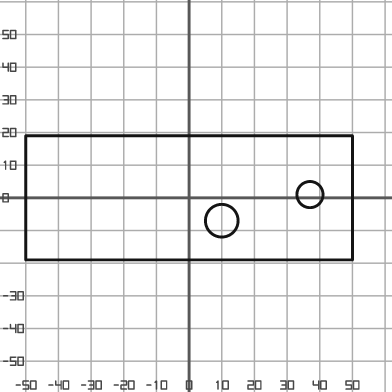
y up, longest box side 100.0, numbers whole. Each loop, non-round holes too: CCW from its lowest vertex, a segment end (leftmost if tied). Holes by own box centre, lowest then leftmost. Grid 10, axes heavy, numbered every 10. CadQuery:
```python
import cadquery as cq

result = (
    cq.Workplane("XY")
    .moveTo(-50.0, -19.0)
    .lineTo(50.0, -19.0)
    .lineTo(50.0, 19.0)
    .lineTo(-50.0, 19.0)
    .close()
    .moveTo(10.0, -7.0)
    .circle(5.0)
    .moveTo(37.0, 1.0)
    .circle(4.0)
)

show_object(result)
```